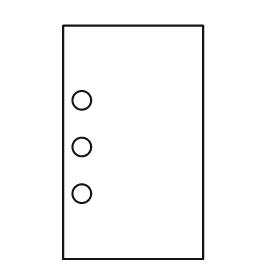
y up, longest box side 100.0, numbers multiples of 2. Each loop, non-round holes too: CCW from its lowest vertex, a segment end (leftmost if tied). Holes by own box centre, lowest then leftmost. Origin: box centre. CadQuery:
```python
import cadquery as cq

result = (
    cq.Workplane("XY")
    .moveTo(-30.0, -50.0)
    .lineTo(30.0, -50.0)
    .lineTo(30.0, 50.0)
    .lineTo(-30.0, 50.0)
    .close()
    .moveTo(-22.0, -22.0)
    .circle(4.0)
    .moveTo(-22.0, -2.0)
    .circle(4.0)
    .moveTo(-22.0, 18.0)
    .circle(4.0)
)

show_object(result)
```